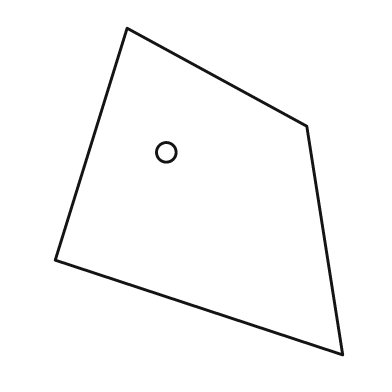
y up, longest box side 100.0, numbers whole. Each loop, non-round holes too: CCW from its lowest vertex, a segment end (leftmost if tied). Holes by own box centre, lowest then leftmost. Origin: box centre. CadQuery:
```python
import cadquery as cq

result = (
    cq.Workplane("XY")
    .moveTo(44.0, -50.0)
    .lineTo(33.0, 20.0)
    .lineTo(-22.0, 50.0)
    .lineTo(-44.0, -21.0)
    .close()
    .moveTo(-10.0, 12.0)
    .circle(3.0)
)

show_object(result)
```